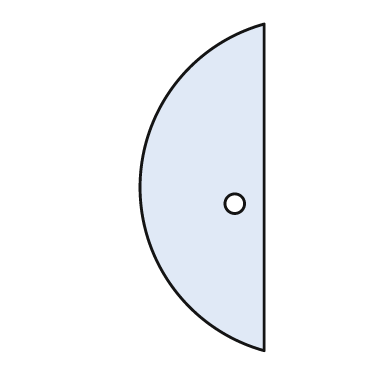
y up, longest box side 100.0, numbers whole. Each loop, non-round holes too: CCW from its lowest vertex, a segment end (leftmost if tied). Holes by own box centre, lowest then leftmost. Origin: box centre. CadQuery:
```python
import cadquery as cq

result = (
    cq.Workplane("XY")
    .moveTo(19.0, -50.0)
    .lineTo(19.0, 50.0)
    .threePointArc((-19.0, 0.0), (19.0, -50.0))
    .close()
    .moveTo(10.0, -5.0)
    .circle(3.0)
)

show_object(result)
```